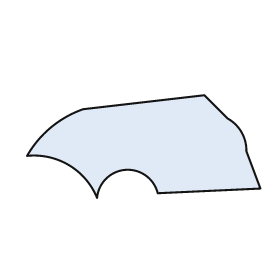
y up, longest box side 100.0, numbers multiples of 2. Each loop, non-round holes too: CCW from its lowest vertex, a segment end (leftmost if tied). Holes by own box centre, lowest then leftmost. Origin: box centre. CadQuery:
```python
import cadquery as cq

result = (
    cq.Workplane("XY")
    .moveTo(-20.0, -22.0)
    .threePointArc((-8.0, -10.0), (6.0, -20.0))
    .lineTo(50.0, -18.0)
    .lineTo(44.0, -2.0)
    .threePointArc((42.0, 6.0), (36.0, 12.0))
    .lineTo(26.0, 22.0)
    .lineTo(-26.0, 16.0)
    .threePointArc((-40.0, 8.0), (-50.0, -4.0))
    .threePointArc((-32.0, -8.0), (-20.0, -22.0))
    .close()
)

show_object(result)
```